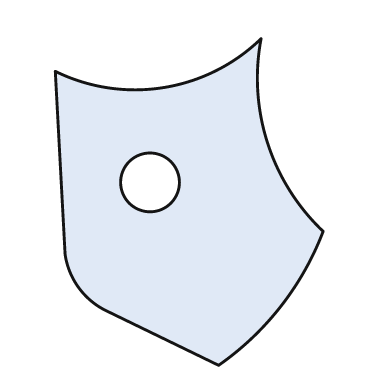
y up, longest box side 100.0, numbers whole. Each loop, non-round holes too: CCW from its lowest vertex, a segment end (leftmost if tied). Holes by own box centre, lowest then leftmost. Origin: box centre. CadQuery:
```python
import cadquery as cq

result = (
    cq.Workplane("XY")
    .moveTo(9.0, -50.0)
    .threePointArc((28.0, -32.0), (41.0, -9.0))
    .threePointArc((24.0, 18.0), (22.0, 50.0))
    .threePointArc((-8.0, 35.0), (-41.0, 40.0))
    .lineTo(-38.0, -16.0)
    .threePointArc((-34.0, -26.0), (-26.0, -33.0))
    .close()
    .moveTo(-12.0, 6.0)
    .circle(9.0)
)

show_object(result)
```